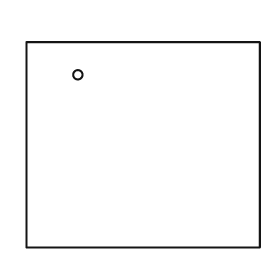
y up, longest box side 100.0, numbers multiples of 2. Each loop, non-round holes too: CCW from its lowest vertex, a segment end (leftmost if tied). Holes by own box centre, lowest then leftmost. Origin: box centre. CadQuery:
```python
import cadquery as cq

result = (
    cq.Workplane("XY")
    .moveTo(-50.0, -44.0)
    .lineTo(50.0, -44.0)
    .lineTo(50.0, 44.0)
    .lineTo(-50.0, 44.0)
    .close()
    .moveTo(-28.0, 30.0)
    .circle(2.0)
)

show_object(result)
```